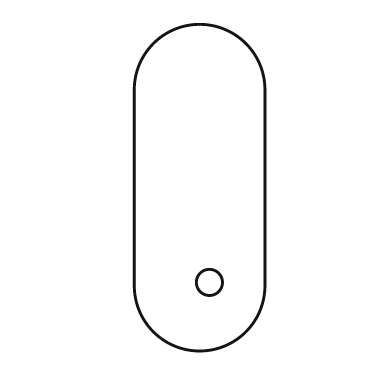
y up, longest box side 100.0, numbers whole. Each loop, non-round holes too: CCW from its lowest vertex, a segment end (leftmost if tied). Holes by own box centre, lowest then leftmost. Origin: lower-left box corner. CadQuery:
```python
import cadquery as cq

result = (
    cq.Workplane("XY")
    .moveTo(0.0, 20.0)
    .threePointArc((20.0, 0.0), (40.0, 20.0))
    .lineTo(40.0, 80.0)
    .threePointArc((20.0, 100.0), (0.0, 80.0))
    .close()
    .moveTo(23.0, 21.0)
    .circle(4.0)
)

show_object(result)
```